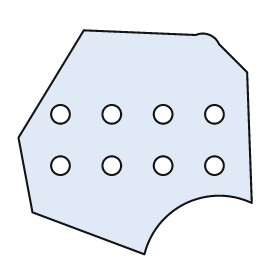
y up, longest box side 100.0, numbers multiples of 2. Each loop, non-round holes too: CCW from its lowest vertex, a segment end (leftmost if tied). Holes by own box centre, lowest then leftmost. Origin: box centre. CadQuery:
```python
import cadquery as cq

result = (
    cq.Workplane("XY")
    .moveTo(4.0, -48.0)
    .threePointArc((22.0, -26.0), (50.0, -26.0))
    .lineTo(48.0, 30.0)
    .lineTo(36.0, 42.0)
    .threePointArc((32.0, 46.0), (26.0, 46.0))
    .lineTo(-22.0, 48.0)
    .lineTo(-50.0, 2.0)
    .lineTo(-44.0, -30.0)
    .close()
    .moveTo(-32.0, -10.0)
    .circle(4.0)
    .moveTo(-10.0, -10.0)
    .circle(4.0)
    .moveTo(12.0, -10.0)
    .circle(4.0)
    .moveTo(34.0, -10.0)
    .circle(4.0)
    .moveTo(-32.0, 12.0)
    .circle(4.0)
    .moveTo(-10.0, 12.0)
    .circle(4.0)
    .moveTo(12.0, 12.0)
    .circle(4.0)
    .moveTo(34.0, 12.0)
    .circle(4.0)
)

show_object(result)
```